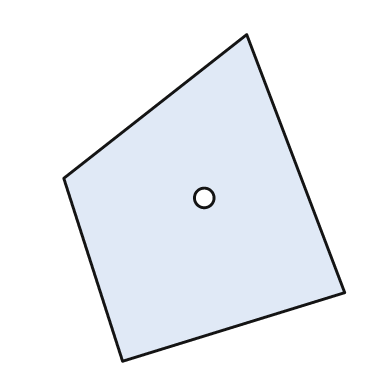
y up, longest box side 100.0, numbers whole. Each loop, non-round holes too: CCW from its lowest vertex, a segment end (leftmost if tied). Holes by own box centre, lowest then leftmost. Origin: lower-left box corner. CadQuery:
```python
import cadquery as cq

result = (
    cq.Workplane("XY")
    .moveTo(18.0, 0.0)
    .lineTo(86.0, 21.0)
    .lineTo(56.0, 100.0)
    .lineTo(0.0, 56.0)
    .close()
    .moveTo(43.0, 50.0)
    .circle(3.0)
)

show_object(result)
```